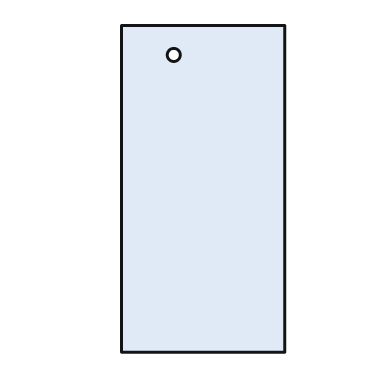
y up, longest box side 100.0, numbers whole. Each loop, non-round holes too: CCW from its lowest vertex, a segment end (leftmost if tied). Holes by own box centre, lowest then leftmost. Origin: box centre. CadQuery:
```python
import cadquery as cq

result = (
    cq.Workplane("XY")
    .moveTo(-25.0, -50.0)
    .lineTo(25.0, -50.0)
    .lineTo(25.0, 50.0)
    .lineTo(-25.0, 50.0)
    .close()
    .moveTo(-9.0, 41.0)
    .circle(2.0)
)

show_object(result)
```